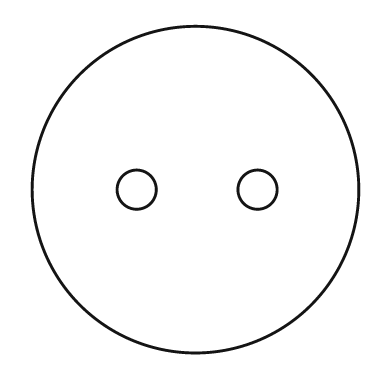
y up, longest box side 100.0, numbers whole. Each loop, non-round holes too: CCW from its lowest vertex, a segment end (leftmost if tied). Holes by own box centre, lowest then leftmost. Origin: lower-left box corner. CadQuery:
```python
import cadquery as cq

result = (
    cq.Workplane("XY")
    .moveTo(50.0, 50.0)
    .circle(50.0)
    .moveTo(32.0, 50.0)
    .circle(6.0)
    .moveTo(69.0, 50.0)
    .circle(6.0)
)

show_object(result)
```